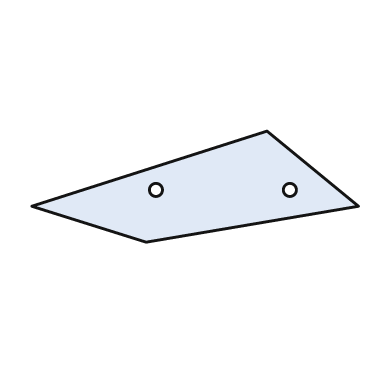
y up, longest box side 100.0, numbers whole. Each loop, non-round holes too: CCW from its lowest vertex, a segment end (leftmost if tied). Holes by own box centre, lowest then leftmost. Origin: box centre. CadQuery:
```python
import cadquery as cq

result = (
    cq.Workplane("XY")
    .moveTo(-15.0, -17.0)
    .lineTo(50.0, -6.0)
    .lineTo(22.0, 17.0)
    .lineTo(-50.0, -6.0)
    .close()
    .moveTo(-12.0, -1.0)
    .circle(2.0)
    .moveTo(29.0, -1.0)
    .circle(2.0)
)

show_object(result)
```